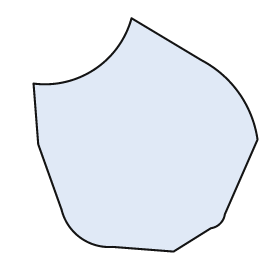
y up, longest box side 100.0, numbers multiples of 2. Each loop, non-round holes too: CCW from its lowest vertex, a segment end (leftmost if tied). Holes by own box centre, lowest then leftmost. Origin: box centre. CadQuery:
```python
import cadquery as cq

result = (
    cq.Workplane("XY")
    .moveTo(12.0, -50.0)
    .lineTo(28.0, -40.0)
    .threePointArc((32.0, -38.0), (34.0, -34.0))
    .lineTo(48.0, -2.0)
    .threePointArc((40.0, 18.0), (24.0, 32.0))
    .lineTo(-6.0, 50.0)
    .threePointArc((-22.0, 28.0), (-48.0, 22.0))
    .lineTo(-46.0, -4.0)
    .lineTo(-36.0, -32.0)
    .threePointArc((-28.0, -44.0), (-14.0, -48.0))
    .close()
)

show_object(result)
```